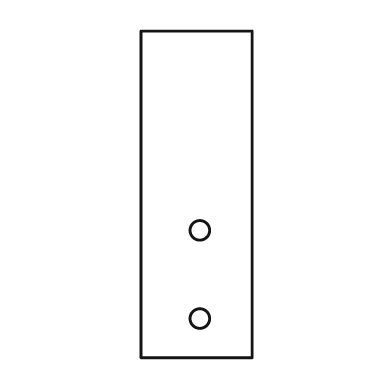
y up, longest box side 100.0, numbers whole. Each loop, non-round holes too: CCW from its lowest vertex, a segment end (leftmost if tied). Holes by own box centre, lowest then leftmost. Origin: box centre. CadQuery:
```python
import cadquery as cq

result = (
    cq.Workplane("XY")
    .moveTo(-17.0, -50.0)
    .lineTo(17.0, -50.0)
    .lineTo(17.0, 50.0)
    .lineTo(-17.0, 50.0)
    .close()
    .moveTo(1.0, -38.0)
    .circle(3.0)
    .moveTo(1.0, -11.0)
    .circle(3.0)
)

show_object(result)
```